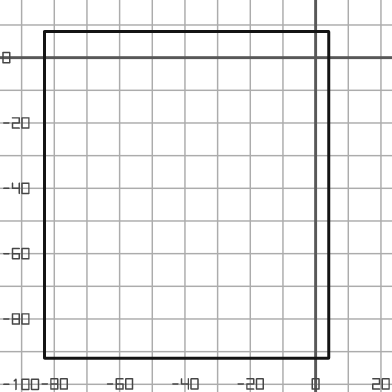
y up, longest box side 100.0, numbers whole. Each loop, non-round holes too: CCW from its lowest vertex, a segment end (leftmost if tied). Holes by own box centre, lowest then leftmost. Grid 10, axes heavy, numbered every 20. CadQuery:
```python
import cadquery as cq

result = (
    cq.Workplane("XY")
    .moveTo(-83.0, -92.0)
    .lineTo(4.0, -92.0)
    .lineTo(4.0, 8.0)
    .lineTo(-83.0, 8.0)
    .close()
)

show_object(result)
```